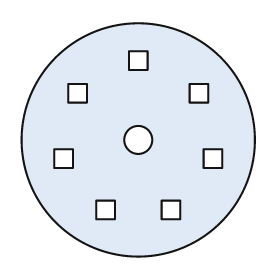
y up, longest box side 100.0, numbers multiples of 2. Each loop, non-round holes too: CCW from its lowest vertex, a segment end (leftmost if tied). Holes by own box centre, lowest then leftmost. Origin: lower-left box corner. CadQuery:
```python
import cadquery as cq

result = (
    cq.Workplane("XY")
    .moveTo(50.0, 50.0)
    .circle(50.0)
    .moveTo(32.0, 16.0)
    .lineTo(40.0, 16.0)
    .lineTo(40.0, 24.0)
    .lineTo(32.0, 24.0)
    .close()
    .moveTo(60.0, 16.0)
    .lineTo(68.0, 16.0)
    .lineTo(68.0, 24.0)
    .lineTo(60.0, 24.0)
    .close()
    .moveTo(14.0, 38.0)
    .lineTo(22.0, 38.0)
    .lineTo(22.0, 46.0)
    .lineTo(14.0, 46.0)
    .close()
    .moveTo(78.0, 38.0)
    .lineTo(86.0, 38.0)
    .lineTo(86.0, 46.0)
    .lineTo(78.0, 46.0)
    .close()
    .moveTo(50.0, 50.0)
    .circle(6.0)
    .moveTo(20.0, 66.0)
    .lineTo(28.0, 66.0)
    .lineTo(28.0, 74.0)
    .lineTo(20.0, 74.0)
    .close()
    .moveTo(72.0, 66.0)
    .lineTo(80.0, 66.0)
    .lineTo(80.0, 74.0)
    .lineTo(72.0, 74.0)
    .close()
    .moveTo(46.0, 80.0)
    .lineTo(54.0, 80.0)
    .lineTo(54.0, 88.0)
    .lineTo(46.0, 88.0)
    .close()
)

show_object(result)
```